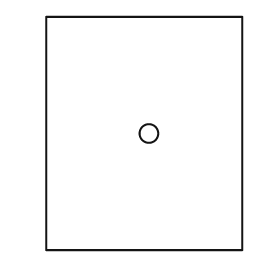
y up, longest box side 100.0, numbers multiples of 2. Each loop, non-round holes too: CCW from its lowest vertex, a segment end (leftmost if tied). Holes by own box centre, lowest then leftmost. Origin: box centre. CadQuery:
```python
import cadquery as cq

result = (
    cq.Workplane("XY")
    .moveTo(-42.0, -50.0)
    .lineTo(42.0, -50.0)
    .lineTo(42.0, 50.0)
    .lineTo(-42.0, 50.0)
    .close()
    .moveTo(2.0, 0.0)
    .circle(4.0)
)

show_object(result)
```